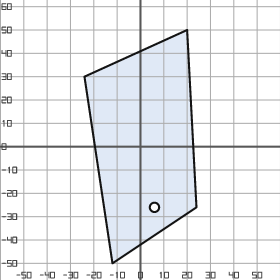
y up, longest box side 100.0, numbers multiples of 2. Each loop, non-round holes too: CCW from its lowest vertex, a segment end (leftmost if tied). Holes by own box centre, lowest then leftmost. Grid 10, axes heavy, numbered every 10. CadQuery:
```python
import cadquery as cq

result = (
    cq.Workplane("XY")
    .moveTo(-12.0, -50.0)
    .lineTo(24.0, -26.0)
    .lineTo(20.0, 50.0)
    .lineTo(-24.0, 30.0)
    .close()
    .moveTo(6.0, -26.0)
    .circle(2.0)
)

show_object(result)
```